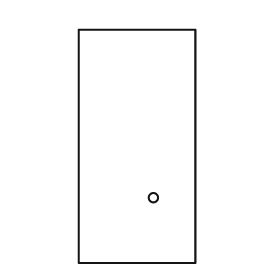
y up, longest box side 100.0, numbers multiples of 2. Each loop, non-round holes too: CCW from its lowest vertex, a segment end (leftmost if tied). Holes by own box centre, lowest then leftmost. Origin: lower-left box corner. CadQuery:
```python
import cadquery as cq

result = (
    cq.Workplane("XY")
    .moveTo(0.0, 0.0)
    .lineTo(50.0, 0.0)
    .lineTo(50.0, 100.0)
    .lineTo(0.0, 100.0)
    .close()
    .moveTo(32.0, 28.0)
    .circle(2.0)
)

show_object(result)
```